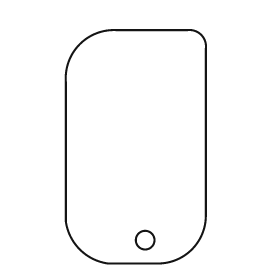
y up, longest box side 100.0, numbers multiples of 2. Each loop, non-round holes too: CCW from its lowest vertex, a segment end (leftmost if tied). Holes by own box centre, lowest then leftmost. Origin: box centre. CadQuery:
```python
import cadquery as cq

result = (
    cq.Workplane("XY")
    .moveTo(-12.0, -50.0)
    .lineTo(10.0, -50.0)
    .threePointArc((24.0, -44.0), (30.0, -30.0))
    .lineTo(30.0, 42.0)
    .threePointArc((28.0, 48.0), (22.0, 50.0))
    .lineTo(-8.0, 50.0)
    .threePointArc((-24.0, 44.0), (-30.0, 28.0))
    .lineTo(-30.0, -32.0)
    .threePointArc((-24.0, -44.0), (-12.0, -50.0))
    .close()
    .moveTo(4.0, -40.0)
    .circle(4.0)
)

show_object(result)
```